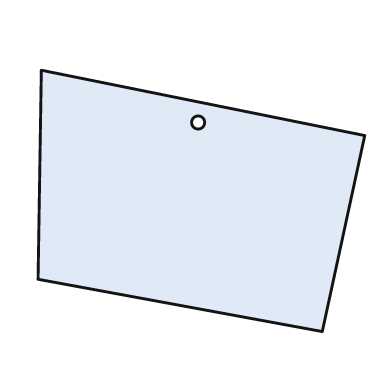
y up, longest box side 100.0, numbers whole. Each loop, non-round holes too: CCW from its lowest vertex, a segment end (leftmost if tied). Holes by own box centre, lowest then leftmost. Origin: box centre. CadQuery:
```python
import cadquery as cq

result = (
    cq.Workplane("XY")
    .moveTo(37.0, -40.0)
    .lineTo(50.0, 20.0)
    .lineTo(-49.0, 40.0)
    .lineTo(-50.0, -24.0)
    .close()
    .moveTo(-1.0, 24.0)
    .circle(2.0)
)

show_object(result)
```